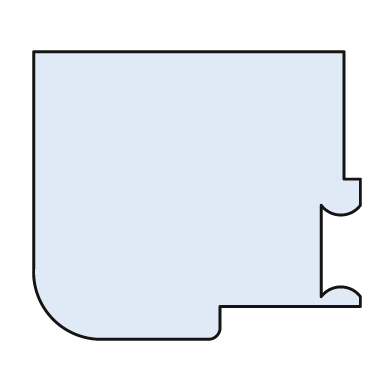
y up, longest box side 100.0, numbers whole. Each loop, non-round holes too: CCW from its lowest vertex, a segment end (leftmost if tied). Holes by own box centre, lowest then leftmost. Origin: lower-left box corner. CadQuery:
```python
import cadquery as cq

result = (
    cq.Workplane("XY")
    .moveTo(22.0, 0.0)
    .lineTo(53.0, 0.0)
    .threePointArc((56.0, 1.0), (57.0, 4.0))
    .lineTo(57.0, 10.0)
    .lineTo(100.0, 10.0)
    .lineTo(100.0, 13.0)
    .threePointArc((94.0, 16.0), (88.0, 13.0))
    .lineTo(88.0, 41.0)
    .threePointArc((94.0, 38.0), (100.0, 41.0))
    .lineTo(100.0, 49.0)
    .lineTo(95.0, 49.0)
    .lineTo(95.0, 88.0)
    .lineTo(0.0, 88.0)
    .lineTo(0.0, 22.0)
    .threePointArc((6.0, 6.0), (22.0, 0.0))
    .close()
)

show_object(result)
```